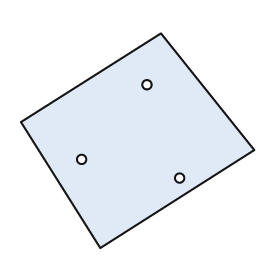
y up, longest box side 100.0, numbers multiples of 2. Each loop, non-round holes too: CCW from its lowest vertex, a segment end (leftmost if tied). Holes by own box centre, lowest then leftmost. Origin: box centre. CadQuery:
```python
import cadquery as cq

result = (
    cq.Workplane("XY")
    .moveTo(-16.0, -46.0)
    .lineTo(50.0, -4.0)
    .lineTo(10.0, 46.0)
    .lineTo(-50.0, 8.0)
    .close()
    .moveTo(18.0, -16.0)
    .circle(2.0)
    .moveTo(-24.0, -8.0)
    .circle(2.0)
    .moveTo(4.0, 24.0)
    .circle(2.0)
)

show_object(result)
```